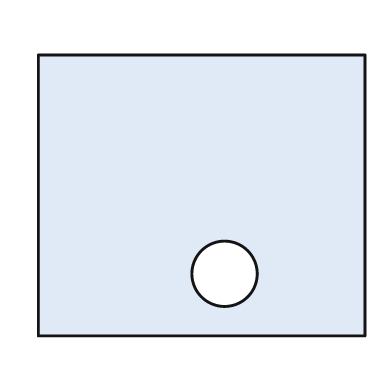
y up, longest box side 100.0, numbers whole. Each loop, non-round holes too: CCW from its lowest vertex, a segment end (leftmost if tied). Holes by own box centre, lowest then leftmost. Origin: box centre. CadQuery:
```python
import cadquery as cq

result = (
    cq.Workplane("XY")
    .moveTo(-50.0, -43.0)
    .lineTo(50.0, -43.0)
    .lineTo(50.0, 43.0)
    .lineTo(-50.0, 43.0)
    .close()
    .moveTo(7.0, -24.0)
    .circle(10.0)
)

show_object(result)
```